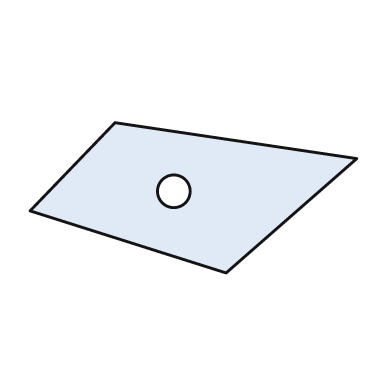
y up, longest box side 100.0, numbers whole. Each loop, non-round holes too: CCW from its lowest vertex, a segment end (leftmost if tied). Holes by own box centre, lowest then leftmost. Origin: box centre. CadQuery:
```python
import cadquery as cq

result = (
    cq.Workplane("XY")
    .moveTo(10.0, -23.0)
    .lineTo(50.0, 12.0)
    .lineTo(-24.0, 23.0)
    .lineTo(-50.0, -4.0)
    .close()
    .moveTo(-6.0, 2.0)
    .circle(5.0)
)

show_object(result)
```